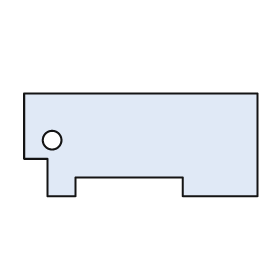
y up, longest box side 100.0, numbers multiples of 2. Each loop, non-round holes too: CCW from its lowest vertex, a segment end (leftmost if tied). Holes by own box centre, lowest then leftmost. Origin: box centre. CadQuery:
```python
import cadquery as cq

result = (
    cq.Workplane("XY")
    .moveTo(-40.0, -22.0)
    .lineTo(-28.0, -22.0)
    .lineTo(-28.0, -14.0)
    .lineTo(18.0, -14.0)
    .lineTo(18.0, -22.0)
    .lineTo(50.0, -22.0)
    .lineTo(50.0, 22.0)
    .lineTo(-50.0, 22.0)
    .lineTo(-50.0, -6.0)
    .lineTo(-40.0, -6.0)
    .close()
    .moveTo(-38.0, 2.0)
    .circle(4.0)
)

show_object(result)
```